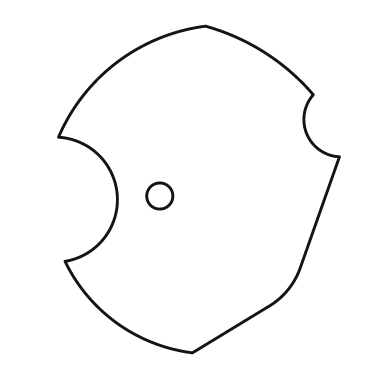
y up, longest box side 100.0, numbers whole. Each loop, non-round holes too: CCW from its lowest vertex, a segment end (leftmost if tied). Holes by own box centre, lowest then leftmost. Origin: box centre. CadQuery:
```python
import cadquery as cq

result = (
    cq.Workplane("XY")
    .moveTo(-2.0, -50.0)
    .lineTo(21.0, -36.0)
    .threePointArc((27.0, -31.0), (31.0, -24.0))
    .lineTo(43.0, 10.0)
    .threePointArc((33.0, 17.0), (35.0, 29.0))
    .threePointArc((20.0, 42.0), (2.0, 50.0))
    .threePointArc((-25.0, 39.0), (-43.0, 16.0))
    .threePointArc((-25.0, -2.0), (-41.0, -22.0))
    .threePointArc((-25.0, -41.0), (-2.0, -50.0))
    .close()
    .moveTo(-12.0, -2.0)
    .circle(4.0)
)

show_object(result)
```